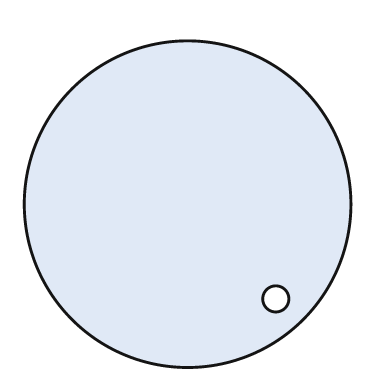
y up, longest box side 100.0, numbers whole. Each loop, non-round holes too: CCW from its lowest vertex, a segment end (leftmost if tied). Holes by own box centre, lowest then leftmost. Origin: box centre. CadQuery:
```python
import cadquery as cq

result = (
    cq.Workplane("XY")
    .moveTo(0.0, 0.0)
    .circle(50.0)
    .moveTo(27.0, -29.0)
    .circle(4.0)
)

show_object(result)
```